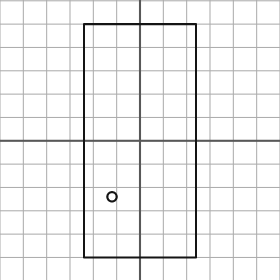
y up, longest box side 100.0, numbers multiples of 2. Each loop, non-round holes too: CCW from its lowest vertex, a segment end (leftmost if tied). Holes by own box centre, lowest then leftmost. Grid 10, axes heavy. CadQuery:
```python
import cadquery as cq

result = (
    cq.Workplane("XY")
    .moveTo(-24.0, -50.0)
    .lineTo(24.0, -50.0)
    .lineTo(24.0, 50.0)
    .lineTo(-24.0, 50.0)
    .close()
    .moveTo(-12.0, -24.0)
    .circle(2.0)
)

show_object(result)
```